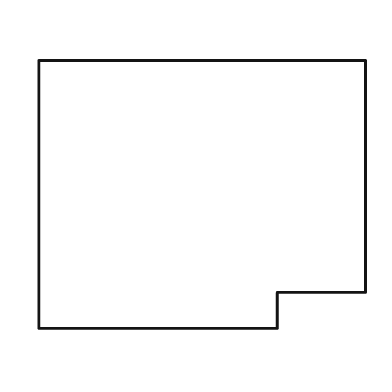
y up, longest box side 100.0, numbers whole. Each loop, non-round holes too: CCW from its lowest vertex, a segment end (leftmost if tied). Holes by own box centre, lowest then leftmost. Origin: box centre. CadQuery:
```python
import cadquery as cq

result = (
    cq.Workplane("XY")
    .moveTo(-50.0, -41.0)
    .lineTo(23.0, -41.0)
    .lineTo(23.0, -30.0)
    .lineTo(50.0, -30.0)
    .lineTo(50.0, 41.0)
    .lineTo(-50.0, 41.0)
    .close()
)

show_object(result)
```